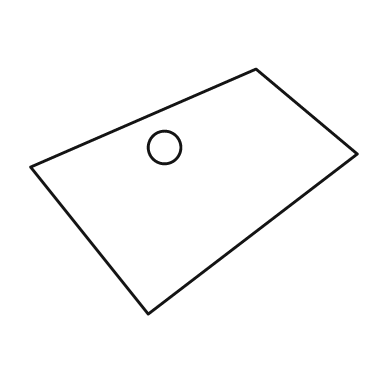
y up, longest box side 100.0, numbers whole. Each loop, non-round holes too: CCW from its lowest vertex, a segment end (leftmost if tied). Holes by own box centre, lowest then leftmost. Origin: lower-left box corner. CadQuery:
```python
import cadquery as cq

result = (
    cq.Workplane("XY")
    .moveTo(36.0, 0.0)
    .lineTo(100.0, 49.0)
    .lineTo(69.0, 75.0)
    .lineTo(0.0, 45.0)
    .close()
    .moveTo(41.0, 51.0)
    .circle(5.0)
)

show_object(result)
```